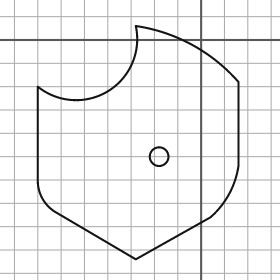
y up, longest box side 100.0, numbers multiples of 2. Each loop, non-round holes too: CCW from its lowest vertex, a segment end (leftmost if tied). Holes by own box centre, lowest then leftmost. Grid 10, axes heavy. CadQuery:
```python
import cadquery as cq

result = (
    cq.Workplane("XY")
    .moveTo(-28.0, -94.0)
    .lineTo(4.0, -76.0)
    .threePointArc((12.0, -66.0), (16.0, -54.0))
    .lineTo(16.0, -18.0)
    .threePointArc((-4.0, -2.0), (-28.0, 6.0))
    .threePointArc((-40.0, -22.0), (-70.0, -20.0))
    .lineTo(-70.0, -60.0)
    .threePointArc((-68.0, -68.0), (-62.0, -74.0))
    .close()
    .moveTo(-18.0, -50.0)
    .circle(4.0)
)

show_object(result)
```